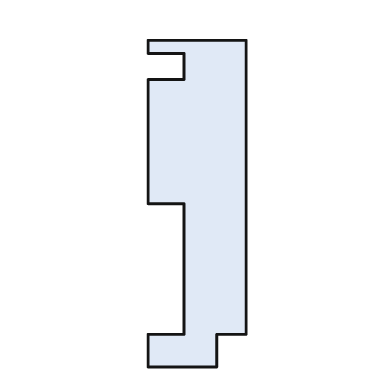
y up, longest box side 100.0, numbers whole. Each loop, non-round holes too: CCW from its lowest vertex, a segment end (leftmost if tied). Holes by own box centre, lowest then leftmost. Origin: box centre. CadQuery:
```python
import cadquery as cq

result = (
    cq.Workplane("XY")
    .moveTo(-15.0, -50.0)
    .lineTo(6.0, -50.0)
    .lineTo(6.0, -40.0)
    .lineTo(15.0, -40.0)
    .lineTo(15.0, 50.0)
    .lineTo(-15.0, 50.0)
    .lineTo(-15.0, 46.0)
    .lineTo(-4.0, 46.0)
    .lineTo(-4.0, 38.0)
    .lineTo(-15.0, 38.0)
    .lineTo(-15.0, 0.0)
    .lineTo(-4.0, 0.0)
    .lineTo(-4.0, -40.0)
    .lineTo(-15.0, -40.0)
    .close()
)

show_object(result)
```